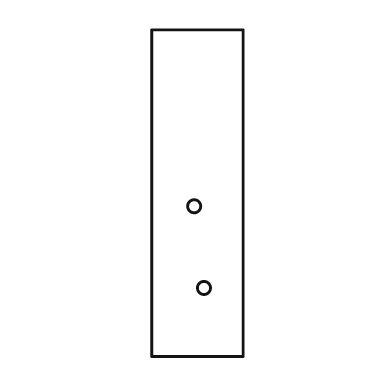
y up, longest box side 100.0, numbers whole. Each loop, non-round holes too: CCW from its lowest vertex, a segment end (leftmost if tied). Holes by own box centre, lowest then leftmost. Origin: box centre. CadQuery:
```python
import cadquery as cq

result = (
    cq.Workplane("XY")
    .moveTo(-14.0, -50.0)
    .lineTo(14.0, -50.0)
    .lineTo(14.0, 50.0)
    .lineTo(-14.0, 50.0)
    .close()
    .moveTo(2.0, -29.0)
    .circle(2.0)
    .moveTo(-1.0, -4.0)
    .circle(2.0)
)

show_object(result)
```